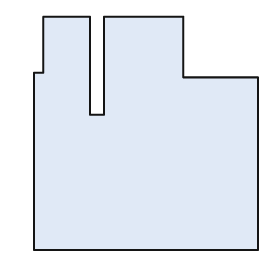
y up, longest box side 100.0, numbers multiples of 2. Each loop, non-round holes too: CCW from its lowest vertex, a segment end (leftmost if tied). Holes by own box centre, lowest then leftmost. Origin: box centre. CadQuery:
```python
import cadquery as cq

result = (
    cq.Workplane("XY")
    .moveTo(-48.0, -50.0)
    .lineTo(48.0, -50.0)
    .lineTo(48.0, 24.0)
    .lineTo(16.0, 24.0)
    .lineTo(16.0, 50.0)
    .lineTo(-18.0, 50.0)
    .lineTo(-18.0, 8.0)
    .lineTo(-24.0, 8.0)
    .lineTo(-24.0, 50.0)
    .lineTo(-44.0, 50.0)
    .lineTo(-44.0, 26.0)
    .lineTo(-48.0, 26.0)
    .close()
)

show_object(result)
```